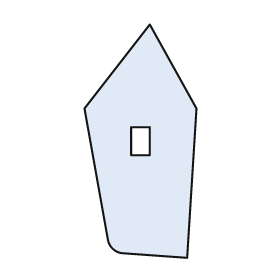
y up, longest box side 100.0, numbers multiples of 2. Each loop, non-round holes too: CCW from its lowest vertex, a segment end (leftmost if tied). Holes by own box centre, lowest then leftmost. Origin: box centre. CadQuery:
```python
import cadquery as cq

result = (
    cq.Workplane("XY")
    .moveTo(20.0, -50.0)
    .lineTo(24.0, 14.0)
    .lineTo(4.0, 50.0)
    .lineTo(-24.0, 14.0)
    .lineTo(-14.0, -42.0)
    .threePointArc((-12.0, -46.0), (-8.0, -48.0))
    .close()
    .moveTo(-4.0, -6.0)
    .lineTo(4.0, -6.0)
    .lineTo(4.0, 6.0)
    .lineTo(-4.0, 6.0)
    .close()
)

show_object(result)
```